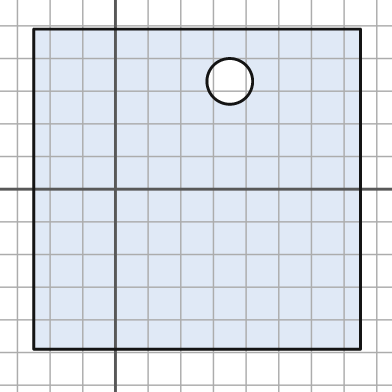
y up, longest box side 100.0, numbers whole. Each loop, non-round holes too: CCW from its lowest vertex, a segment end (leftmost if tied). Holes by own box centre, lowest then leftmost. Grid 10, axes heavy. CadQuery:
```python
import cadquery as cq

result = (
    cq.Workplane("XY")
    .moveTo(-25.0, -49.0)
    .lineTo(75.0, -49.0)
    .lineTo(75.0, 49.0)
    .lineTo(-25.0, 49.0)
    .close()
    .moveTo(35.0, 33.0)
    .circle(7.0)
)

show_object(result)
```